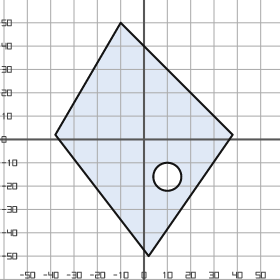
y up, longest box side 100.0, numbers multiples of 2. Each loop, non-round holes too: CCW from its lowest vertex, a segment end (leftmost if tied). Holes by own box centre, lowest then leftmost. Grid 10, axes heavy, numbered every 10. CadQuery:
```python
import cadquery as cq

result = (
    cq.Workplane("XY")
    .moveTo(2.0, -50.0)
    .lineTo(38.0, 2.0)
    .lineTo(-10.0, 50.0)
    .lineTo(-38.0, 2.0)
    .close()
    .moveTo(10.0, -16.0)
    .circle(6.0)
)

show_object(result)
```